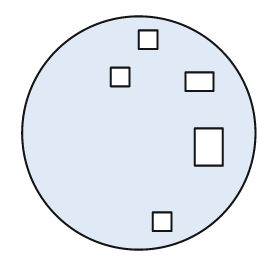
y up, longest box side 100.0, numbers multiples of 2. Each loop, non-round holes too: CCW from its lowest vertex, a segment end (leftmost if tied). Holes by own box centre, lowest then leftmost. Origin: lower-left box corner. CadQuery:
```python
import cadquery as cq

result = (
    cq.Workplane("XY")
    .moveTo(50.0, 50.0)
    .circle(50.0)
    .moveTo(56.0, 8.0)
    .lineTo(64.0, 8.0)
    .lineTo(64.0, 16.0)
    .lineTo(56.0, 16.0)
    .close()
    .moveTo(74.0, 36.0)
    .lineTo(86.0, 36.0)
    .lineTo(86.0, 52.0)
    .lineTo(74.0, 52.0)
    .close()
    .moveTo(70.0, 68.0)
    .lineTo(82.0, 68.0)
    .lineTo(82.0, 76.0)
    .lineTo(70.0, 76.0)
    .close()
    .moveTo(38.0, 70.0)
    .lineTo(46.0, 70.0)
    .lineTo(46.0, 78.0)
    .lineTo(38.0, 78.0)
    .close()
    .moveTo(50.0, 86.0)
    .lineTo(58.0, 86.0)
    .lineTo(58.0, 94.0)
    .lineTo(50.0, 94.0)
    .close()
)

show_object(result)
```